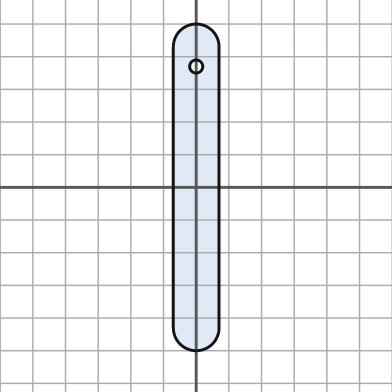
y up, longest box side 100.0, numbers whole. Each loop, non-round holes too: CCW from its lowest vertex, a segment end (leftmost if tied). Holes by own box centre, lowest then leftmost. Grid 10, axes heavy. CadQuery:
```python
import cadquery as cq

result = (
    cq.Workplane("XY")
    .moveTo(-7.0, -43.0)
    .threePointArc((0.0, -50.0), (7.0, -43.0))
    .lineTo(7.0, 43.0)
    .threePointArc((0.0, 50.0), (-7.0, 43.0))
    .close()
    .moveTo(0.0, 37.0)
    .circle(2.0)
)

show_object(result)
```